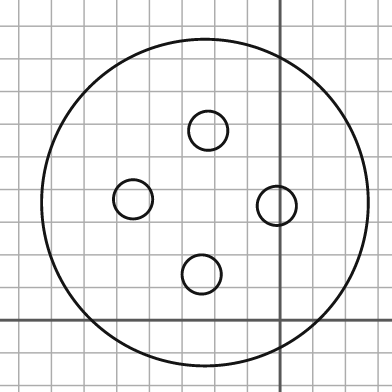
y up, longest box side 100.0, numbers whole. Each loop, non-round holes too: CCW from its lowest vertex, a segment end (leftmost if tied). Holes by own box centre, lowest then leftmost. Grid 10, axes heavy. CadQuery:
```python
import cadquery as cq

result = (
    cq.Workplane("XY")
    .moveTo(-23.0, 36.0)
    .circle(50.0)
    .moveTo(-24.0, 14.0)
    .circle(6.0)
    .moveTo(-1.0, 35.0)
    .circle(6.0)
    .moveTo(-45.0, 37.0)
    .circle(6.0)
    .moveTo(-22.0, 58.0)
    .circle(6.0)
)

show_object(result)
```